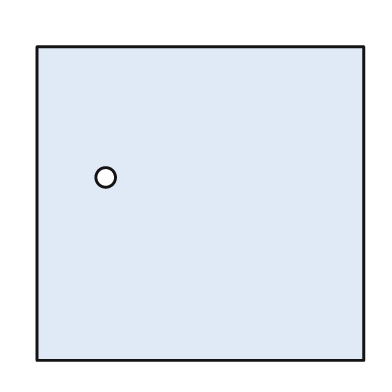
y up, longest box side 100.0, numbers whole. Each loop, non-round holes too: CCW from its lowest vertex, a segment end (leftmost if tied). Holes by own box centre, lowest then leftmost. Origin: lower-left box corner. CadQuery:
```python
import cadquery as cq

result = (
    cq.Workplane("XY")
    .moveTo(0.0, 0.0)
    .lineTo(100.0, 0.0)
    .lineTo(100.0, 96.0)
    .lineTo(0.0, 96.0)
    .close()
    .moveTo(21.0, 56.0)
    .circle(3.0)
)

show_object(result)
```